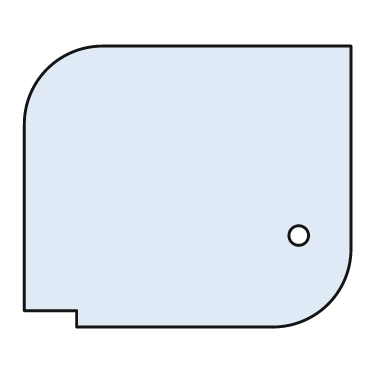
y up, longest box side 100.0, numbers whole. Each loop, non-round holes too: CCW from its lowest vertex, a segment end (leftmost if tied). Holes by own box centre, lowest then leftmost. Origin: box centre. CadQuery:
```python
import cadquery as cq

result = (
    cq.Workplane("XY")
    .moveTo(-34.0, -43.0)
    .lineTo(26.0, -43.0)
    .threePointArc((43.0, -36.0), (50.0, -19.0))
    .lineTo(50.0, 43.0)
    .lineTo(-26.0, 43.0)
    .threePointArc((-43.0, 36.0), (-50.0, 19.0))
    .lineTo(-50.0, -38.0)
    .lineTo(-34.0, -38.0)
    .close()
    .moveTo(34.0, -15.0)
    .circle(3.0)
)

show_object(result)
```